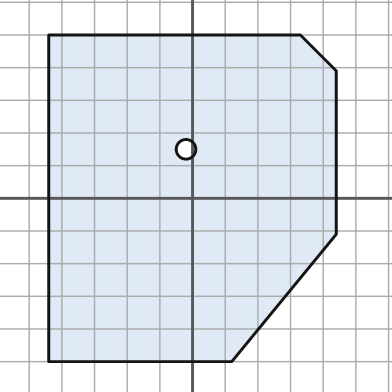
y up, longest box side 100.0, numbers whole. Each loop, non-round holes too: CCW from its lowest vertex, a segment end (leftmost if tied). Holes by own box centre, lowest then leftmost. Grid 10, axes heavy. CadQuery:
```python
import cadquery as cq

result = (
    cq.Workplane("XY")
    .moveTo(-44.0, -50.0)
    .lineTo(12.0, -50.0)
    .lineTo(44.0, -11.0)
    .lineTo(44.0, 39.0)
    .lineTo(33.0, 50.0)
    .lineTo(-44.0, 50.0)
    .close()
    .moveTo(-2.0, 15.0)
    .circle(3.0)
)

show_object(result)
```